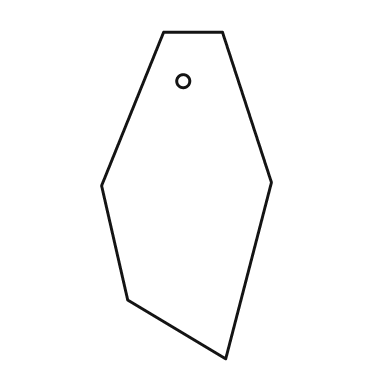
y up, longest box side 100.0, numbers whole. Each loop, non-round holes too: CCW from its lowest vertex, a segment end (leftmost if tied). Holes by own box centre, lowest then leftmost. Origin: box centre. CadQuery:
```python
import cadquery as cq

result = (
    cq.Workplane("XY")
    .moveTo(12.0, -50.0)
    .lineTo(26.0, 4.0)
    .lineTo(11.0, 50.0)
    .lineTo(-7.0, 50.0)
    .lineTo(-26.0, 3.0)
    .lineTo(-18.0, -32.0)
    .close()
    .moveTo(-1.0, 35.0)
    .circle(2.0)
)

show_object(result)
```